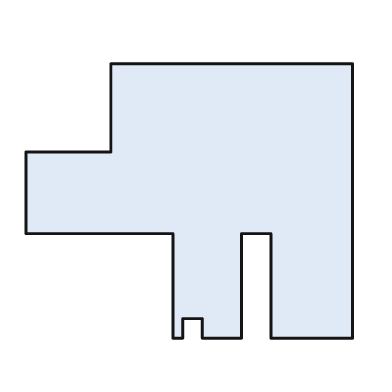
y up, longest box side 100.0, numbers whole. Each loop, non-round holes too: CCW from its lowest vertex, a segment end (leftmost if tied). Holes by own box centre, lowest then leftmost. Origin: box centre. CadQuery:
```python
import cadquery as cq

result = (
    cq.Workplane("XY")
    .moveTo(-5.0, -42.0)
    .lineTo(-2.0, -42.0)
    .lineTo(-2.0, -36.0)
    .lineTo(4.0, -36.0)
    .lineTo(4.0, -42.0)
    .lineTo(16.0, -42.0)
    .lineTo(16.0, -10.0)
    .lineTo(25.0, -10.0)
    .lineTo(25.0, -42.0)
    .lineTo(50.0, -42.0)
    .lineTo(50.0, 42.0)
    .lineTo(-24.0, 42.0)
    .lineTo(-24.0, 15.0)
    .lineTo(-50.0, 15.0)
    .lineTo(-50.0, -10.0)
    .lineTo(-5.0, -10.0)
    .close()
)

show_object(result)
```